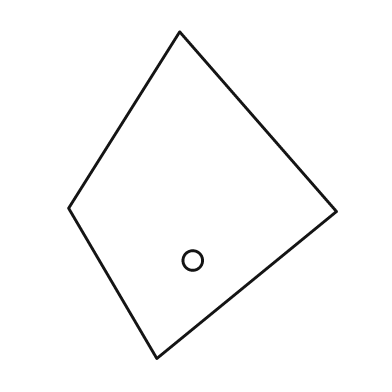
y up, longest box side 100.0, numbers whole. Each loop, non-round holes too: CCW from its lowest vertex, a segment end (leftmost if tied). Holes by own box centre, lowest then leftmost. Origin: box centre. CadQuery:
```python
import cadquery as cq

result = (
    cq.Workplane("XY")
    .moveTo(-14.0, -50.0)
    .lineTo(41.0, -5.0)
    .lineTo(-7.0, 50.0)
    .lineTo(-41.0, -4.0)
    .close()
    .moveTo(-3.0, -20.0)
    .circle(3.0)
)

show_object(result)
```